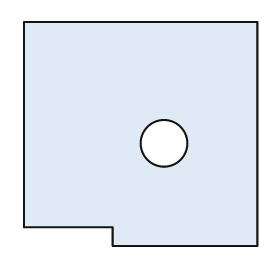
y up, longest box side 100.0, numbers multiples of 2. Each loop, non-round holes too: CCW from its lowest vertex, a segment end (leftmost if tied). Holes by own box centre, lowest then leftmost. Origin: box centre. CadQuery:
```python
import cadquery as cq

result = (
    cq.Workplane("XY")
    .moveTo(-12.0, -48.0)
    .lineTo(50.0, -48.0)
    .lineTo(50.0, 48.0)
    .lineTo(-50.0, 48.0)
    .lineTo(-50.0, -40.0)
    .lineTo(-12.0, -40.0)
    .close()
    .moveTo(10.0, -4.0)
    .circle(10.0)
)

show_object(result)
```